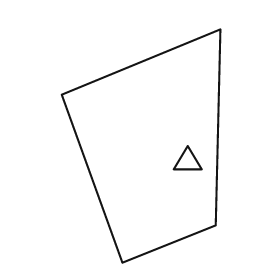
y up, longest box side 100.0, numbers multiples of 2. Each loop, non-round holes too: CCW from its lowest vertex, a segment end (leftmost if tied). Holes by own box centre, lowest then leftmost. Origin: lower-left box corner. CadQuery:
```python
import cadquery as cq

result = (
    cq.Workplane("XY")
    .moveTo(26.0, 0.0)
    .lineTo(66.0, 16.0)
    .lineTo(68.0, 100.0)
    .lineTo(0.0, 72.0)
    .close()
    .moveTo(48.0, 40.0)
    .lineTo(60.0, 40.0)
    .lineTo(54.0, 50.0)
    .close()
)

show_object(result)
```